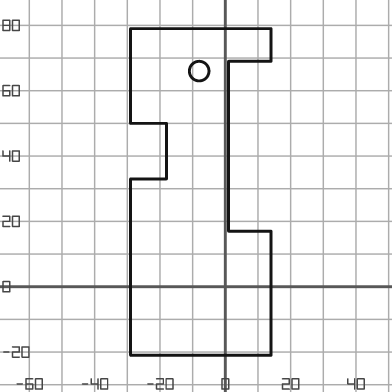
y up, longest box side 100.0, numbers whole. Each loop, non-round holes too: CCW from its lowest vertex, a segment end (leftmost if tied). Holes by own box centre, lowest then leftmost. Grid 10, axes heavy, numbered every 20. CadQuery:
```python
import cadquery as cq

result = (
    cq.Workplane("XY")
    .moveTo(-29.0, -21.0)
    .lineTo(14.0, -21.0)
    .lineTo(14.0, 17.0)
    .lineTo(1.0, 17.0)
    .lineTo(1.0, 69.0)
    .lineTo(14.0, 69.0)
    .lineTo(14.0, 79.0)
    .lineTo(-29.0, 79.0)
    .lineTo(-29.0, 50.0)
    .lineTo(-18.0, 50.0)
    .lineTo(-18.0, 33.0)
    .lineTo(-29.0, 33.0)
    .close()
    .moveTo(-8.0, 66.0)
    .circle(3.0)
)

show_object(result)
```